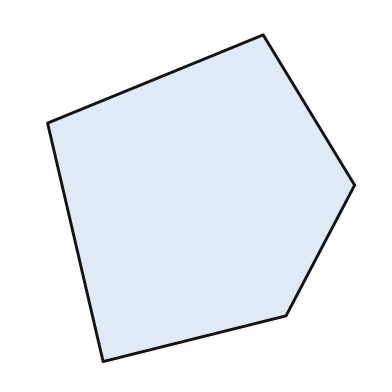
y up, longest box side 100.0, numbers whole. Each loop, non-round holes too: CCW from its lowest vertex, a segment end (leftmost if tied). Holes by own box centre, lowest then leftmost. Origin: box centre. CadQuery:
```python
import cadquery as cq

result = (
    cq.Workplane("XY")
    .moveTo(-30.0, -50.0)
    .lineTo(26.0, -36.0)
    .lineTo(47.0, 4.0)
    .lineTo(19.0, 50.0)
    .lineTo(-47.0, 23.0)
    .close()
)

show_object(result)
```